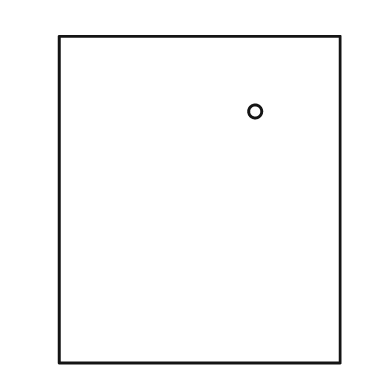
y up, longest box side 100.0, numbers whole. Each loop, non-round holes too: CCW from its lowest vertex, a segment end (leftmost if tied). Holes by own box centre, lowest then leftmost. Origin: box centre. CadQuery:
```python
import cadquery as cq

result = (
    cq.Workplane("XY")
    .moveTo(-43.0, -50.0)
    .lineTo(43.0, -50.0)
    .lineTo(43.0, 50.0)
    .lineTo(-43.0, 50.0)
    .close()
    .moveTo(17.0, 27.0)
    .circle(2.0)
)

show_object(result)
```